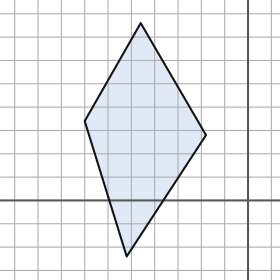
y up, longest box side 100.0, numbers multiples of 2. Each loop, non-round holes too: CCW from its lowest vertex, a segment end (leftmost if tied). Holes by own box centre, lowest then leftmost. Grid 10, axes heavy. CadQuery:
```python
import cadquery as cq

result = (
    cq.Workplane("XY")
    .moveTo(-52.0, -24.0)
    .lineTo(-18.0, 28.0)
    .lineTo(-46.0, 76.0)
    .lineTo(-70.0, 34.0)
    .close()
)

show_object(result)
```